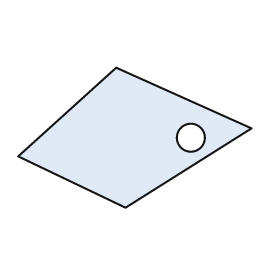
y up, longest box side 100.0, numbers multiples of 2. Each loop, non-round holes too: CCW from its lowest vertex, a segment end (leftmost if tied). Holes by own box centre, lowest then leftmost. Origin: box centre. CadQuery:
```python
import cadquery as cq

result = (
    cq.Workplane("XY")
    .moveTo(-4.0, -30.0)
    .lineTo(50.0, 4.0)
    .lineTo(-8.0, 30.0)
    .lineTo(-50.0, -8.0)
    .close()
    .moveTo(24.0, 0.0)
    .circle(6.0)
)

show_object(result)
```